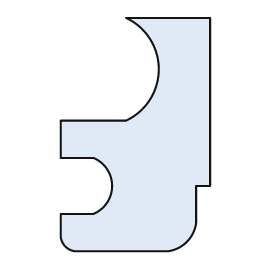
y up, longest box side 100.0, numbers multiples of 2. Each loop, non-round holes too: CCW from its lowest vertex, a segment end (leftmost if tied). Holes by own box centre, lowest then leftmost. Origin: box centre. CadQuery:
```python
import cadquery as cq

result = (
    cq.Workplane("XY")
    .moveTo(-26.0, -50.0)
    .lineTo(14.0, -50.0)
    .threePointArc((22.0, -46.0), (26.0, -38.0))
    .lineTo(26.0, -22.0)
    .lineTo(32.0, -22.0)
    .lineTo(32.0, 50.0)
    .lineTo(-4.0, 50.0)
    .threePointArc((10.0, 28.0), (-4.0, 6.0))
    .lineTo(-32.0, 6.0)
    .lineTo(-32.0, -10.0)
    .lineTo(-18.0, -10.0)
    .threePointArc((-10.0, -22.0), (-18.0, -34.0))
    .lineTo(-32.0, -34.0)
    .lineTo(-32.0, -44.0)
    .threePointArc((-30.0, -48.0), (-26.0, -50.0))
    .close()
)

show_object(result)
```